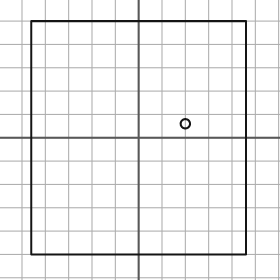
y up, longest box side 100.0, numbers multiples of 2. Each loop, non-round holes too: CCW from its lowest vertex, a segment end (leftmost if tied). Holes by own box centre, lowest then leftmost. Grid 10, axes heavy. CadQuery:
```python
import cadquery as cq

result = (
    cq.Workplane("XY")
    .moveTo(-46.0, -50.0)
    .lineTo(46.0, -50.0)
    .lineTo(46.0, 50.0)
    .lineTo(-46.0, 50.0)
    .close()
    .moveTo(20.0, 6.0)
    .circle(2.0)
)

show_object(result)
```